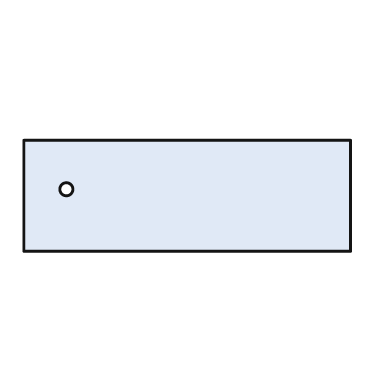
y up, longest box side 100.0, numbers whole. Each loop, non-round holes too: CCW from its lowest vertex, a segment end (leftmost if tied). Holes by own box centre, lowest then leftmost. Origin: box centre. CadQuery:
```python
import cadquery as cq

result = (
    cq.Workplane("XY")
    .moveTo(-50.0, -17.0)
    .lineTo(50.0, -17.0)
    .lineTo(50.0, 17.0)
    .lineTo(-50.0, 17.0)
    .close()
    .moveTo(-37.0, 2.0)
    .circle(2.0)
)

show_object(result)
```